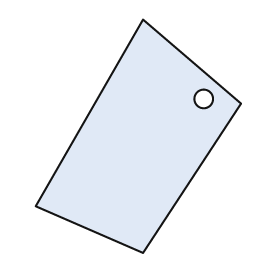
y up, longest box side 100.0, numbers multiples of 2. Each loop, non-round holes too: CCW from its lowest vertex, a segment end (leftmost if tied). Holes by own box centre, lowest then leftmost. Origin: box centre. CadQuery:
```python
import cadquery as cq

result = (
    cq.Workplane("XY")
    .moveTo(2.0, -50.0)
    .lineTo(44.0, 14.0)
    .lineTo(2.0, 50.0)
    .lineTo(-44.0, -30.0)
    .close()
    .moveTo(28.0, 16.0)
    .circle(4.0)
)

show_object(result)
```